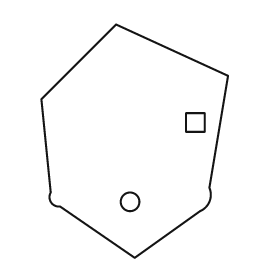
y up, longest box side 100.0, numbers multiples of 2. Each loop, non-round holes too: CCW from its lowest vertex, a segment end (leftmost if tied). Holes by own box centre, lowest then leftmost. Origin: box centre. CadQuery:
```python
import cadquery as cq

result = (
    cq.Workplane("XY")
    .moveTo(0.0, -50.0)
    .lineTo(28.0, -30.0)
    .threePointArc((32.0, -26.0), (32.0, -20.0))
    .lineTo(40.0, 28.0)
    .lineTo(-8.0, 50.0)
    .lineTo(-40.0, 18.0)
    .lineTo(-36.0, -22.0)
    .threePointArc((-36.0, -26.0), (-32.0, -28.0))
    .close()
    .moveTo(-2.0, -26.0)
    .circle(4.0)
    .moveTo(22.0, 4.0)
    .lineTo(30.0, 4.0)
    .lineTo(30.0, 12.0)
    .lineTo(22.0, 12.0)
    .close()
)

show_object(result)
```